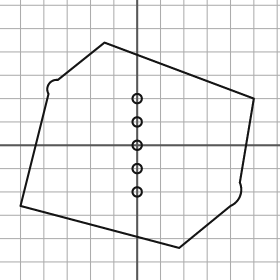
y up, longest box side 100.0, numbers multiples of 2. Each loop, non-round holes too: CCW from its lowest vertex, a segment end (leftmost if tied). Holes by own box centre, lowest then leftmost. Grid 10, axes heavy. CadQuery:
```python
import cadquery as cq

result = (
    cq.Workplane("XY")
    .moveTo(18.0, -44.0)
    .lineTo(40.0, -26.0)
    .threePointArc((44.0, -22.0), (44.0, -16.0))
    .lineTo(50.0, 20.0)
    .lineTo(-14.0, 44.0)
    .lineTo(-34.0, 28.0)
    .threePointArc((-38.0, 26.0), (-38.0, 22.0))
    .lineTo(-50.0, -26.0)
    .close()
    .moveTo(0.0, -20.0)
    .circle(2.0)
    .moveTo(0.0, -10.0)
    .circle(2.0)
    .moveTo(0.0, 0.0)
    .circle(2.0)
    .moveTo(0.0, 10.0)
    .circle(2.0)
    .moveTo(0.0, 20.0)
    .circle(2.0)
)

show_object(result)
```